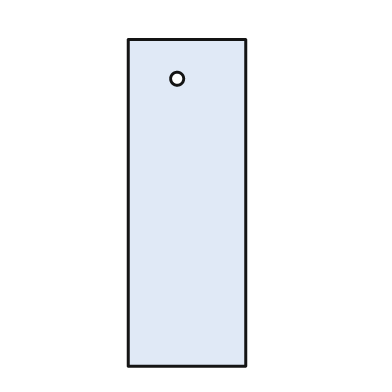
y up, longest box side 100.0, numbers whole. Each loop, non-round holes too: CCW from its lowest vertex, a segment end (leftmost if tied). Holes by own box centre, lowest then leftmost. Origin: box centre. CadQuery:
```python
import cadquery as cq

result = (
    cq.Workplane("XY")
    .moveTo(-18.0, -50.0)
    .lineTo(18.0, -50.0)
    .lineTo(18.0, 50.0)
    .lineTo(-18.0, 50.0)
    .close()
    .moveTo(-3.0, 38.0)
    .circle(2.0)
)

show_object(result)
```